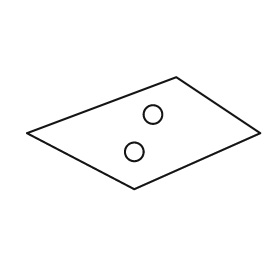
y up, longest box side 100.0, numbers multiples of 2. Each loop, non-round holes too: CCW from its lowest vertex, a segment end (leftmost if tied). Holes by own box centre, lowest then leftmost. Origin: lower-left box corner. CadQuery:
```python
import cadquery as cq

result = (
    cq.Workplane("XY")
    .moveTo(46.0, 0.0)
    .lineTo(100.0, 24.0)
    .lineTo(64.0, 48.0)
    .lineTo(0.0, 24.0)
    .close()
    .moveTo(46.0, 16.0)
    .circle(4.0)
    .moveTo(54.0, 32.0)
    .circle(4.0)
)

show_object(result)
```